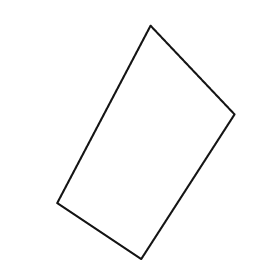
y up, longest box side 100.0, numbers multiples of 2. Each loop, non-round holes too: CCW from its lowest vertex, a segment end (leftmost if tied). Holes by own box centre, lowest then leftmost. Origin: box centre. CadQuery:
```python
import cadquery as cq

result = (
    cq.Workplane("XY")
    .moveTo(-2.0, -50.0)
    .lineTo(38.0, 12.0)
    .lineTo(2.0, 50.0)
    .lineTo(-38.0, -26.0)
    .close()
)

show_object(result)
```